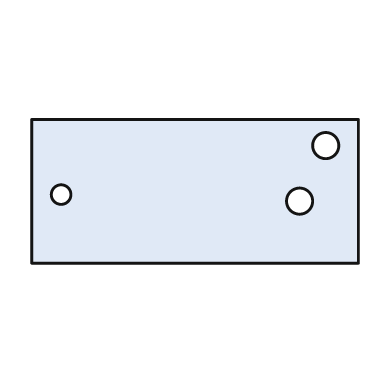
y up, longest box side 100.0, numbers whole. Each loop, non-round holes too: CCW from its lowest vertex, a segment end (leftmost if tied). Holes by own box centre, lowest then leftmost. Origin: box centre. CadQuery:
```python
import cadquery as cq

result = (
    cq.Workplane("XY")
    .moveTo(-50.0, -22.0)
    .lineTo(50.0, -22.0)
    .lineTo(50.0, 22.0)
    .lineTo(-50.0, 22.0)
    .close()
    .moveTo(32.0, -3.0)
    .circle(4.0)
    .moveTo(-41.0, -1.0)
    .circle(3.0)
    .moveTo(40.0, 14.0)
    .circle(4.0)
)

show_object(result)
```